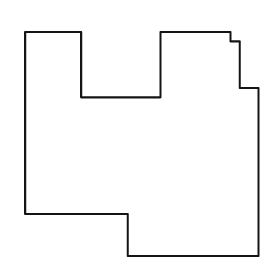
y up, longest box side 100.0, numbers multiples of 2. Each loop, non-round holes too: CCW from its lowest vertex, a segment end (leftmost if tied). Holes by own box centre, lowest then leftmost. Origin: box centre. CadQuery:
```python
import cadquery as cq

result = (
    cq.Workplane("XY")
    .moveTo(-6.0, -48.0)
    .lineTo(50.0, -48.0)
    .lineTo(50.0, 24.0)
    .lineTo(42.0, 24.0)
    .lineTo(42.0, 44.0)
    .lineTo(38.0, 44.0)
    .lineTo(38.0, 48.0)
    .lineTo(8.0, 48.0)
    .lineTo(8.0, 20.0)
    .lineTo(-26.0, 20.0)
    .lineTo(-26.0, 48.0)
    .lineTo(-50.0, 48.0)
    .lineTo(-50.0, -30.0)
    .lineTo(-6.0, -30.0)
    .close()
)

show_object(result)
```